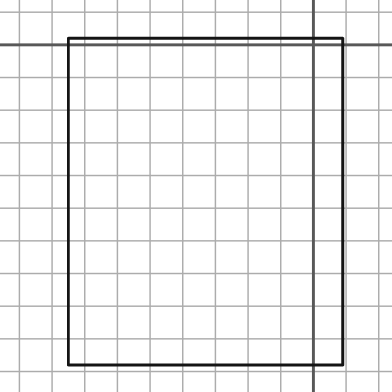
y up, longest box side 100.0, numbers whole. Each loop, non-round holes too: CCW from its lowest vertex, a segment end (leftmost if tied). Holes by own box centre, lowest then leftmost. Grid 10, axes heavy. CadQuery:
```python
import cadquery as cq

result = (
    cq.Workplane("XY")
    .moveTo(-75.0, -98.0)
    .lineTo(9.0, -98.0)
    .lineTo(9.0, 2.0)
    .lineTo(-75.0, 2.0)
    .close()
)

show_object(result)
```